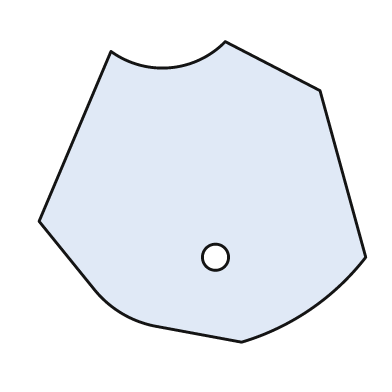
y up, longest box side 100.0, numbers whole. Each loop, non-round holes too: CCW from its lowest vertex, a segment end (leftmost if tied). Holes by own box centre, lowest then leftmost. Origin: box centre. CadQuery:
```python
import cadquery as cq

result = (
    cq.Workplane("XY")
    .moveTo(12.0, -46.0)
    .threePointArc((33.0, -36.0), (50.0, -20.0))
    .lineTo(36.0, 31.0)
    .lineTo(7.0, 46.0)
    .threePointArc((-10.0, 38.0), (-28.0, 43.0))
    .lineTo(-50.0, -9.0)
    .lineTo(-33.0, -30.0)
    .threePointArc((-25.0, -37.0), (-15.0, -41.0))
    .close()
    .moveTo(4.0, -20.0)
    .circle(4.0)
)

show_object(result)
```